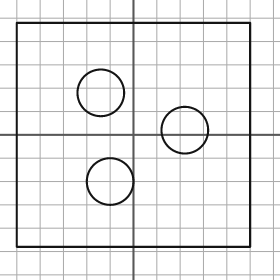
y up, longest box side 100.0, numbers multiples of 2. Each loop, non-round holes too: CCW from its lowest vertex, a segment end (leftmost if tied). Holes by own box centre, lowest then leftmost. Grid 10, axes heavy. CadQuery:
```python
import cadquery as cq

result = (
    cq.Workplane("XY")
    .moveTo(-50.0, -48.0)
    .lineTo(50.0, -48.0)
    .lineTo(50.0, 48.0)
    .lineTo(-50.0, 48.0)
    .close()
    .moveTo(-10.0, -20.0)
    .circle(10.0)
    .moveTo(22.0, 2.0)
    .circle(10.0)
    .moveTo(-14.0, 18.0)
    .circle(10.0)
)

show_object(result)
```